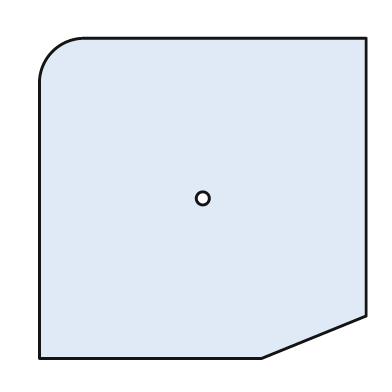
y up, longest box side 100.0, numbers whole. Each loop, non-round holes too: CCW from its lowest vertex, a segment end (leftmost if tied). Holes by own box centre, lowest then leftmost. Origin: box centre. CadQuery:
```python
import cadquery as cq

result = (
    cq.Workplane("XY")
    .moveTo(-50.0, -49.0)
    .lineTo(18.0, -49.0)
    .lineTo(50.0, -36.0)
    .lineTo(50.0, 49.0)
    .lineTo(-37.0, 49.0)
    .threePointArc((-46.0, 45.0), (-50.0, 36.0))
    .close()
    .moveTo(0.0, 0.0)
    .circle(2.0)
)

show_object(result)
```